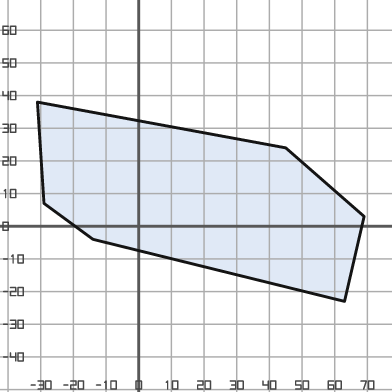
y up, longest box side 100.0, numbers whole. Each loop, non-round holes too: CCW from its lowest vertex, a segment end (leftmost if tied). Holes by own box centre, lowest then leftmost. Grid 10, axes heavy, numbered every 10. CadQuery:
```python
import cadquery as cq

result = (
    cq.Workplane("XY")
    .moveTo(63.0, -23.0)
    .lineTo(69.0, 3.0)
    .lineTo(45.0, 24.0)
    .lineTo(-31.0, 38.0)
    .lineTo(-29.0, 7.0)
    .lineTo(-14.0, -4.0)
    .close()
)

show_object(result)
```